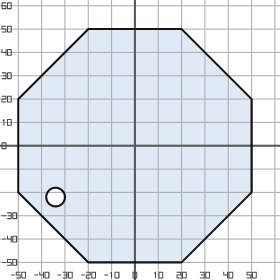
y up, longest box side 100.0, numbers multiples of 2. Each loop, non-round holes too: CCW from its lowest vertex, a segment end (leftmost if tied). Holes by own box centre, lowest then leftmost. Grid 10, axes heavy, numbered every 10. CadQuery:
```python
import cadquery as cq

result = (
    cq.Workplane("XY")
    .moveTo(-20.0, -50.0)
    .lineTo(20.0, -50.0)
    .lineTo(50.0, -20.0)
    .lineTo(50.0, 20.0)
    .lineTo(20.0, 50.0)
    .lineTo(-20.0, 50.0)
    .lineTo(-50.0, 20.0)
    .lineTo(-50.0, -20.0)
    .close()
    .moveTo(-34.0, -22.0)
    .circle(4.0)
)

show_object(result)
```